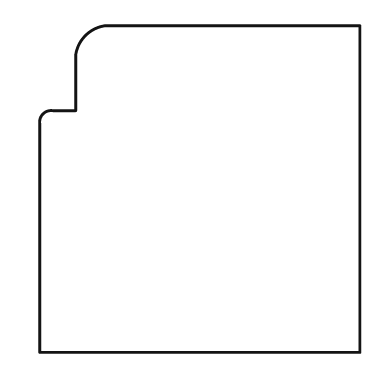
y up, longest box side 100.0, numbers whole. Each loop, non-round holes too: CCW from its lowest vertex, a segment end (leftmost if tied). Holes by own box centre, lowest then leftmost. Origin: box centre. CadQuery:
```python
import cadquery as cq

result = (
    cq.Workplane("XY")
    .moveTo(-49.0, -50.0)
    .lineTo(49.0, -50.0)
    .lineTo(49.0, 50.0)
    .lineTo(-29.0, 50.0)
    .threePointArc((-35.0, 47.0), (-38.0, 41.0))
    .lineTo(-38.0, 24.0)
    .lineTo(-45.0, 24.0)
    .threePointArc((-48.0, 23.0), (-49.0, 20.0))
    .close()
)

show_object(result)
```